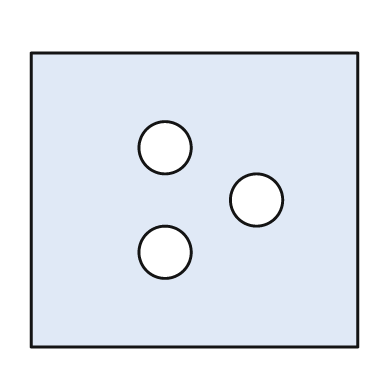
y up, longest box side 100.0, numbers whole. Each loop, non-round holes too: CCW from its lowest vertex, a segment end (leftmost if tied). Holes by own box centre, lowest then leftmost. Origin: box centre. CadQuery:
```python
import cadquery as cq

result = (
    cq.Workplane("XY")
    .moveTo(-50.0, -45.0)
    .lineTo(50.0, -45.0)
    .lineTo(50.0, 45.0)
    .lineTo(-50.0, 45.0)
    .close()
    .moveTo(-9.0, -16.0)
    .circle(8.0)
    .moveTo(19.0, 0.0)
    .circle(8.0)
    .moveTo(-9.0, 16.0)
    .circle(8.0)
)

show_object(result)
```